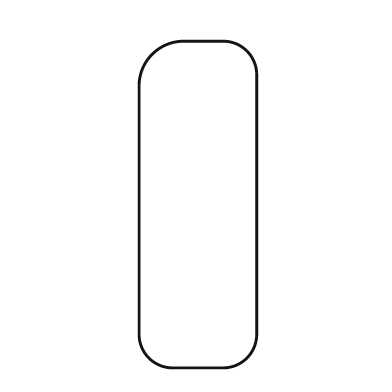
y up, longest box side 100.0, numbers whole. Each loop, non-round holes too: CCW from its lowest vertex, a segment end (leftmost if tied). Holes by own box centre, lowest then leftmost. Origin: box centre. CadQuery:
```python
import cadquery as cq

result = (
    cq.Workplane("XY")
    .moveTo(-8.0, -50.0)
    .lineTo(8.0, -50.0)
    .threePointArc((15.0, -47.0), (18.0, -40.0))
    .lineTo(18.0, 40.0)
    .threePointArc((15.0, 47.0), (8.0, 50.0))
    .lineTo(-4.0, 50.0)
    .threePointArc((-14.0, 46.0), (-18.0, 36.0))
    .lineTo(-18.0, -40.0)
    .threePointArc((-15.0, -47.0), (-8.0, -50.0))
    .close()
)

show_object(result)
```